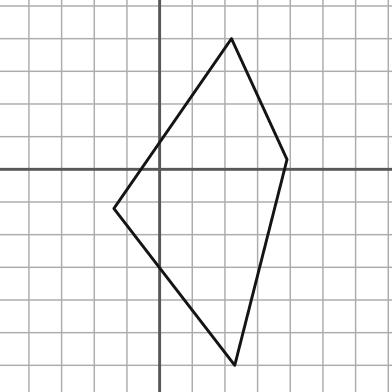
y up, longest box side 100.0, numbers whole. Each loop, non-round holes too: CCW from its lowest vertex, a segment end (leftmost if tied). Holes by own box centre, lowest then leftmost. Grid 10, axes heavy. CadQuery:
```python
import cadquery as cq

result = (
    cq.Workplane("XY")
    .moveTo(23.0, -60.0)
    .lineTo(39.0, 3.0)
    .lineTo(22.0, 40.0)
    .lineTo(-14.0, -12.0)
    .close()
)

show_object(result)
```